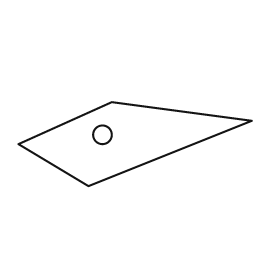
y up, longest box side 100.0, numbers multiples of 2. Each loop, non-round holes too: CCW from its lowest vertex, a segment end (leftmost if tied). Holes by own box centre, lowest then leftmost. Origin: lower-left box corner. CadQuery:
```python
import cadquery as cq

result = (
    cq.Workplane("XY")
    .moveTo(30.0, 0.0)
    .lineTo(100.0, 28.0)
    .lineTo(40.0, 36.0)
    .lineTo(0.0, 18.0)
    .close()
    .moveTo(36.0, 22.0)
    .circle(4.0)
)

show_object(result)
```